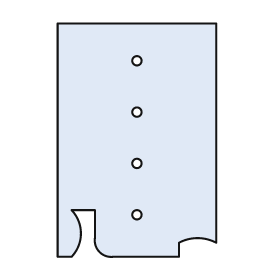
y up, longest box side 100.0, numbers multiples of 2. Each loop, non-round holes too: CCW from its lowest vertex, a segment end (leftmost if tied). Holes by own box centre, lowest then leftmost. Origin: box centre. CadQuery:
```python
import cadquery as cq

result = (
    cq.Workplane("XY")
    .moveTo(-34.0, -50.0)
    .lineTo(-28.0, -50.0)
    .threePointArc((-24.0, -40.0), (-28.0, -30.0))
    .lineTo(-18.0, -30.0)
    .lineTo(-18.0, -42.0)
    .threePointArc((-16.0, -48.0), (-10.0, -50.0))
    .lineTo(18.0, -50.0)
    .lineTo(18.0, -44.0)
    .threePointArc((26.0, -42.0), (34.0, -44.0))
    .lineTo(34.0, 50.0)
    .lineTo(-34.0, 50.0)
    .close()
    .moveTo(0.0, -32.0)
    .circle(2.0)
    .moveTo(0.0, -10.0)
    .circle(2.0)
    .moveTo(0.0, 12.0)
    .circle(2.0)
    .moveTo(0.0, 34.0)
    .circle(2.0)
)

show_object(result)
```